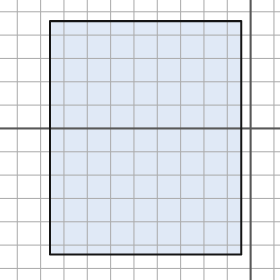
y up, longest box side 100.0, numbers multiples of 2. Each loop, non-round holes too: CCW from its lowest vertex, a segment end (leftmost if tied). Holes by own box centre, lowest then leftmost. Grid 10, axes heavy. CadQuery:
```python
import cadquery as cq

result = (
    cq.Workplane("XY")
    .moveTo(-86.0, -54.0)
    .lineTo(-4.0, -54.0)
    .lineTo(-4.0, 46.0)
    .lineTo(-86.0, 46.0)
    .close()
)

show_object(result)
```